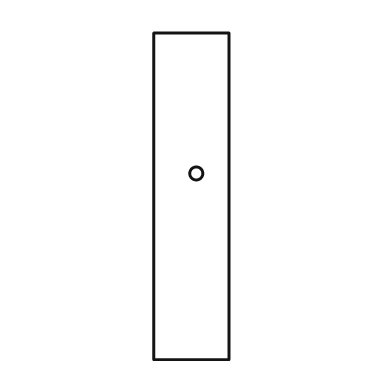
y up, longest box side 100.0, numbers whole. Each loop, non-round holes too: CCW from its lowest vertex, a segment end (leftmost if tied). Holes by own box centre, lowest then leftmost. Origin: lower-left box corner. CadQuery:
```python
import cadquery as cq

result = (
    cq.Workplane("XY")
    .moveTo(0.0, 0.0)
    .lineTo(23.0, 0.0)
    .lineTo(23.0, 100.0)
    .lineTo(0.0, 100.0)
    .close()
    .moveTo(13.0, 57.0)
    .circle(2.0)
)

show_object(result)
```